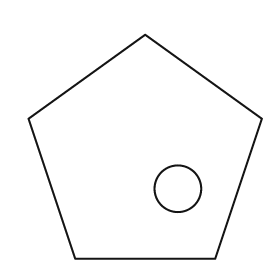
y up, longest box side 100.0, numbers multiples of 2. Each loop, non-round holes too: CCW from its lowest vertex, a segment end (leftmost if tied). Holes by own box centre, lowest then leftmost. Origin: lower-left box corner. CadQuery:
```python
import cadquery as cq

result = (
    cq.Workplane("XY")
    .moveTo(20.0, 0.0)
    .lineTo(80.0, 0.0)
    .lineTo(100.0, 60.0)
    .lineTo(50.0, 96.0)
    .lineTo(0.0, 60.0)
    .close()
    .moveTo(64.0, 30.0)
    .circle(10.0)
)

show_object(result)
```